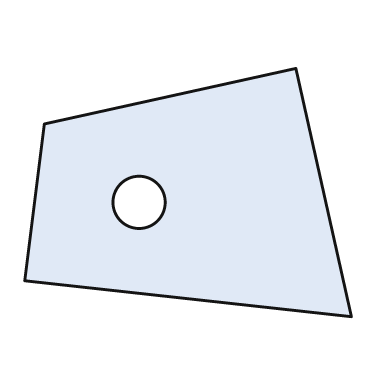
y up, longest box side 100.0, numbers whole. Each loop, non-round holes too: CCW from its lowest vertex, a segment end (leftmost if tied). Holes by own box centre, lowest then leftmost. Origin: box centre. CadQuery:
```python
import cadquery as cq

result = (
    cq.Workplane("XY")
    .moveTo(50.0, -38.0)
    .lineTo(33.0, 38.0)
    .lineTo(-44.0, 21.0)
    .lineTo(-50.0, -27.0)
    .close()
    .moveTo(-15.0, -3.0)
    .circle(8.0)
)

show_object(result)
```